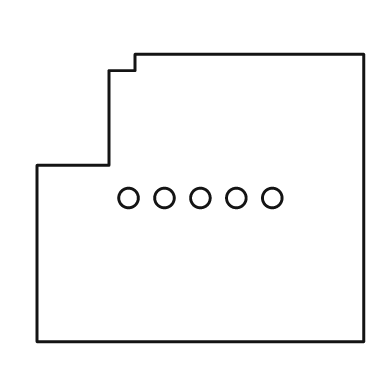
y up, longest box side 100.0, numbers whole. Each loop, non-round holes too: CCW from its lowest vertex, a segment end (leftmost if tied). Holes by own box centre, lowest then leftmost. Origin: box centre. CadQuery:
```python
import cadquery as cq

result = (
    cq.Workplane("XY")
    .moveTo(-50.0, -44.0)
    .lineTo(50.0, -44.0)
    .lineTo(50.0, 44.0)
    .lineTo(-20.0, 44.0)
    .lineTo(-20.0, 39.0)
    .lineTo(-28.0, 39.0)
    .lineTo(-28.0, 10.0)
    .lineTo(-50.0, 10.0)
    .close()
    .moveTo(-22.0, 0.0)
    .circle(3.0)
    .moveTo(-11.0, 0.0)
    .circle(3.0)
    .moveTo(0.0, 0.0)
    .circle(3.0)
    .moveTo(11.0, 0.0)
    .circle(3.0)
    .moveTo(22.0, 0.0)
    .circle(3.0)
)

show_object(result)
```